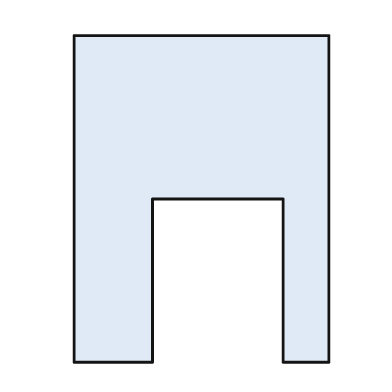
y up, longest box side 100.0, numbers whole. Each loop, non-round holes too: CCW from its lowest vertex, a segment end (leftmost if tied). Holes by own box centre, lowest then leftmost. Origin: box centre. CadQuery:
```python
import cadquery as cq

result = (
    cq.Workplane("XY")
    .moveTo(-39.0, -50.0)
    .lineTo(-15.0, -50.0)
    .lineTo(-15.0, 0.0)
    .lineTo(25.0, 0.0)
    .lineTo(25.0, -50.0)
    .lineTo(39.0, -50.0)
    .lineTo(39.0, 50.0)
    .lineTo(-39.0, 50.0)
    .close()
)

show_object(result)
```